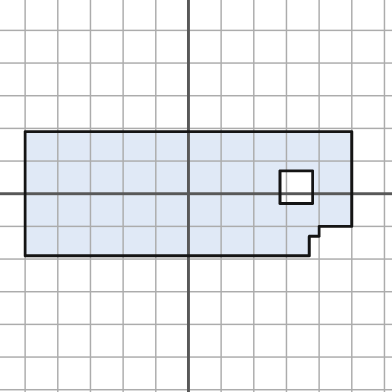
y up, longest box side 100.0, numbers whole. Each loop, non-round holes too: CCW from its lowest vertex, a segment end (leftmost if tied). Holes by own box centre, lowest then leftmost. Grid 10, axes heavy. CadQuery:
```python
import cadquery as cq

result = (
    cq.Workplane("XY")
    .moveTo(-50.0, -19.0)
    .lineTo(37.0, -19.0)
    .lineTo(37.0, -13.0)
    .lineTo(40.0, -13.0)
    .lineTo(40.0, -10.0)
    .lineTo(50.0, -10.0)
    .lineTo(50.0, 19.0)
    .lineTo(-50.0, 19.0)
    .close()
    .moveTo(28.0, -3.0)
    .lineTo(38.0, -3.0)
    .lineTo(38.0, 7.0)
    .lineTo(28.0, 7.0)
    .close()
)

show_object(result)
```